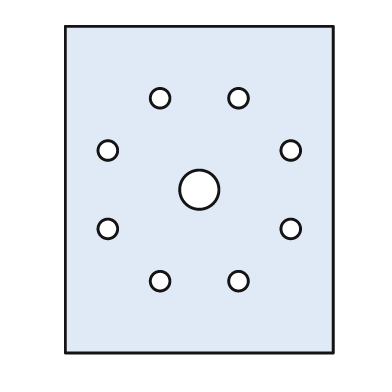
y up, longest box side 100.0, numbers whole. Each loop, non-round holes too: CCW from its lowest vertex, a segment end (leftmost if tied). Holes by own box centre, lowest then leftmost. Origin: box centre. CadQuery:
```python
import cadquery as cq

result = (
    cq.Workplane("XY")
    .moveTo(-41.0, -50.0)
    .lineTo(41.0, -50.0)
    .lineTo(41.0, 50.0)
    .lineTo(-41.0, 50.0)
    .close()
    .moveTo(-12.0, -28.0)
    .circle(3.0)
    .moveTo(12.0, -28.0)
    .circle(3.0)
    .moveTo(-28.0, -12.0)
    .circle(3.0)
    .moveTo(28.0, -12.0)
    .circle(3.0)
    .moveTo(0.0, 0.0)
    .circle(6.0)
    .moveTo(-28.0, 12.0)
    .circle(3.0)
    .moveTo(28.0, 12.0)
    .circle(3.0)
    .moveTo(-12.0, 28.0)
    .circle(3.0)
    .moveTo(12.0, 28.0)
    .circle(3.0)
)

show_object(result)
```